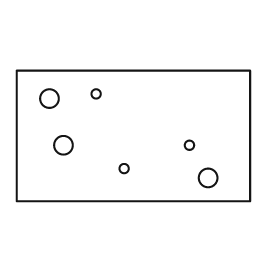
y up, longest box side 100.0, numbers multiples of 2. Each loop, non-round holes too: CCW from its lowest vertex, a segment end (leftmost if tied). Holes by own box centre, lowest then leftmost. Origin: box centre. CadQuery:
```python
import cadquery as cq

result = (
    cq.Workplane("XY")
    .moveTo(-50.0, -28.0)
    .lineTo(50.0, -28.0)
    .lineTo(50.0, 28.0)
    .lineTo(-50.0, 28.0)
    .close()
    .moveTo(32.0, -18.0)
    .circle(4.0)
    .moveTo(-4.0, -14.0)
    .circle(2.0)
    .moveTo(-30.0, -4.0)
    .circle(4.0)
    .moveTo(24.0, -4.0)
    .circle(2.0)
    .moveTo(-36.0, 16.0)
    .circle(4.0)
    .moveTo(-16.0, 18.0)
    .circle(2.0)
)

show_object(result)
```